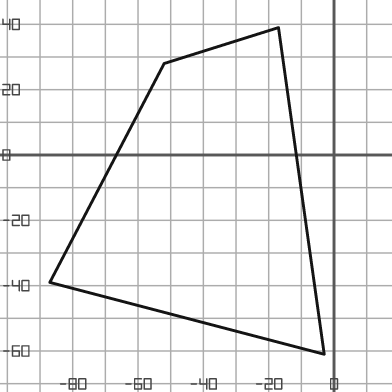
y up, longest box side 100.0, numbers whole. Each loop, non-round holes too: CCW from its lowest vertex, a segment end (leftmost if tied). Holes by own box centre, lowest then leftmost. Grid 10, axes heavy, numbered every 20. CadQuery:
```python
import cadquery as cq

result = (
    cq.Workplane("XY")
    .moveTo(-3.0, -61.0)
    .lineTo(-17.0, 39.0)
    .lineTo(-52.0, 28.0)
    .lineTo(-87.0, -39.0)
    .close()
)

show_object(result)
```